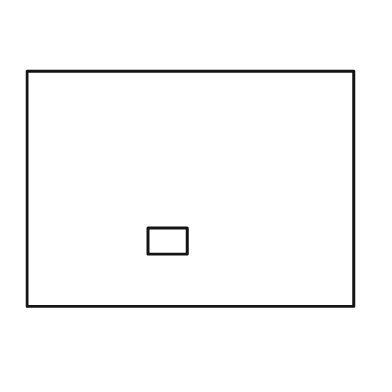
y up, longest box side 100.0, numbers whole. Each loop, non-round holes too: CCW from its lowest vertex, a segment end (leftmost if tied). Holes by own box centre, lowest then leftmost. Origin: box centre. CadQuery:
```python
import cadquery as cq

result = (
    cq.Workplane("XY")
    .moveTo(-50.0, -36.0)
    .lineTo(50.0, -36.0)
    .lineTo(50.0, 36.0)
    .lineTo(-50.0, 36.0)
    .close()
    .moveTo(-13.0, -20.0)
    .lineTo(-1.0, -20.0)
    .lineTo(-1.0, -12.0)
    .lineTo(-13.0, -12.0)
    .close()
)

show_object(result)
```